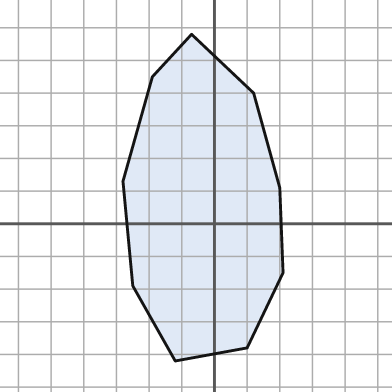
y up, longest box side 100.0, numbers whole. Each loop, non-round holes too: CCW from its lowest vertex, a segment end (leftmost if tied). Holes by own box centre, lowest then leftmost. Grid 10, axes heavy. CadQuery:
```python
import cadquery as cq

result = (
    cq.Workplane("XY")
    .moveTo(-12.0, -42.0)
    .lineTo(10.0, -38.0)
    .lineTo(21.0, -15.0)
    .lineTo(20.0, 11.0)
    .lineTo(12.0, 40.0)
    .lineTo(-7.0, 58.0)
    .lineTo(-19.0, 45.0)
    .lineTo(-28.0, 13.0)
    .lineTo(-25.0, -19.0)
    .close()
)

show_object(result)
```